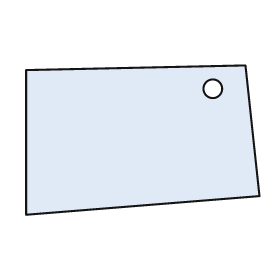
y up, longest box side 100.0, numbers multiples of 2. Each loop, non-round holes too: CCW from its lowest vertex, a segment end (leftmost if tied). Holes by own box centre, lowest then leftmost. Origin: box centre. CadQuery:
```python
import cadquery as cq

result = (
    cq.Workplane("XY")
    .moveTo(-50.0, -32.0)
    .lineTo(50.0, -24.0)
    .lineTo(44.0, 32.0)
    .lineTo(-50.0, 30.0)
    .close()
    .moveTo(30.0, 22.0)
    .circle(4.0)
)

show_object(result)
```